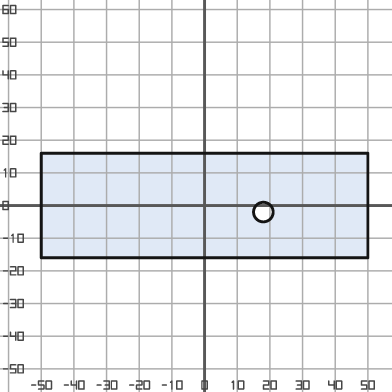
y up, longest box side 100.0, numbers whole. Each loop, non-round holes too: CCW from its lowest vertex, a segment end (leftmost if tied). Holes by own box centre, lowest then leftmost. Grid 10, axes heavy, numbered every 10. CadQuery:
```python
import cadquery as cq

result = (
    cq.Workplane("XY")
    .moveTo(-50.0, -16.0)
    .lineTo(50.0, -16.0)
    .lineTo(50.0, 16.0)
    .lineTo(-50.0, 16.0)
    .close()
    .moveTo(18.0, -2.0)
    .circle(3.0)
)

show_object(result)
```